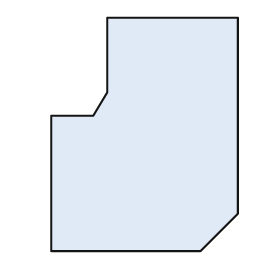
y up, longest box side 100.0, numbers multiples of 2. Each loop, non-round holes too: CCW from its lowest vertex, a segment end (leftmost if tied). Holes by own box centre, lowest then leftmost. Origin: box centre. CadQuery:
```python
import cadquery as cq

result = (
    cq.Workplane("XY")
    .moveTo(-40.0, -50.0)
    .lineTo(24.0, -50.0)
    .lineTo(40.0, -34.0)
    .lineTo(40.0, 50.0)
    .lineTo(-16.0, 50.0)
    .lineTo(-16.0, 18.0)
    .lineTo(-22.0, 8.0)
    .lineTo(-40.0, 8.0)
    .close()
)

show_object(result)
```